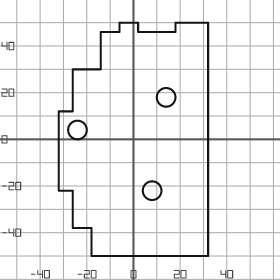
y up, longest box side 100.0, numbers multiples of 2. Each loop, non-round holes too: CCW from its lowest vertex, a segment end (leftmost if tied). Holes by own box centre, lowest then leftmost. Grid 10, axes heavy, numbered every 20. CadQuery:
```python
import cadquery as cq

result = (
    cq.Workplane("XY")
    .moveTo(-18.0, -50.0)
    .lineTo(32.0, -50.0)
    .lineTo(32.0, 50.0)
    .lineTo(18.0, 50.0)
    .lineTo(18.0, 46.0)
    .lineTo(2.0, 46.0)
    .lineTo(2.0, 50.0)
    .lineTo(-6.0, 50.0)
    .lineTo(-6.0, 46.0)
    .lineTo(-14.0, 46.0)
    .lineTo(-14.0, 30.0)
    .lineTo(-26.0, 30.0)
    .lineTo(-26.0, 12.0)
    .lineTo(-32.0, 12.0)
    .lineTo(-32.0, -22.0)
    .lineTo(-26.0, -22.0)
    .lineTo(-26.0, -38.0)
    .lineTo(-18.0, -38.0)
    .close()
    .moveTo(8.0, -22.0)
    .circle(4.0)
    .moveTo(-24.0, 4.0)
    .circle(4.0)
    .moveTo(14.0, 18.0)
    .circle(4.0)
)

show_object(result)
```